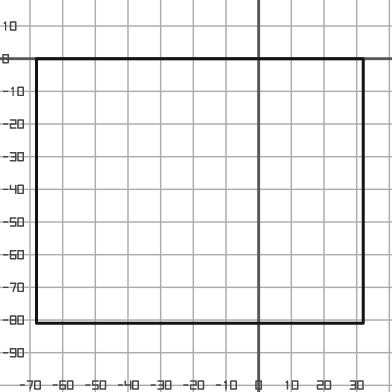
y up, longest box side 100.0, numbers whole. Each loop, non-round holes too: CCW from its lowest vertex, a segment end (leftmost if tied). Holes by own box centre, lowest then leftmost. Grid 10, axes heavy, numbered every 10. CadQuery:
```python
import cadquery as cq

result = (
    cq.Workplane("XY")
    .moveTo(-68.0, -81.0)
    .lineTo(32.0, -81.0)
    .lineTo(32.0, 0.0)
    .lineTo(-68.0, 0.0)
    .close()
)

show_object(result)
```